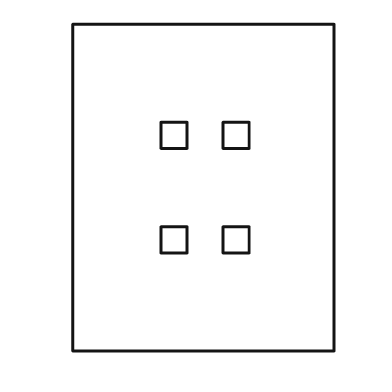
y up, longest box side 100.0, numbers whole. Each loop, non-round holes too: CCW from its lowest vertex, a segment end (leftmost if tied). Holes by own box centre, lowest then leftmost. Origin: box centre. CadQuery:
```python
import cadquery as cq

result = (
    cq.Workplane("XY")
    .moveTo(-40.0, -50.0)
    .lineTo(40.0, -50.0)
    .lineTo(40.0, 50.0)
    .lineTo(-40.0, 50.0)
    .close()
    .moveTo(-13.0, -20.0)
    .lineTo(-5.0, -20.0)
    .lineTo(-5.0, -12.0)
    .lineTo(-13.0, -12.0)
    .close()
    .moveTo(6.0, -20.0)
    .lineTo(14.0, -20.0)
    .lineTo(14.0, -12.0)
    .lineTo(6.0, -12.0)
    .close()
    .moveTo(-13.0, 12.0)
    .lineTo(-5.0, 12.0)
    .lineTo(-5.0, 20.0)
    .lineTo(-13.0, 20.0)
    .close()
    .moveTo(6.0, 12.0)
    .lineTo(14.0, 12.0)
    .lineTo(14.0, 20.0)
    .lineTo(6.0, 20.0)
    .close()
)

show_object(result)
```